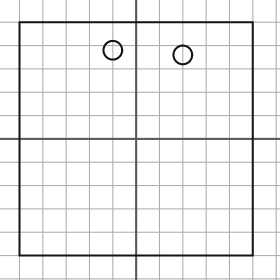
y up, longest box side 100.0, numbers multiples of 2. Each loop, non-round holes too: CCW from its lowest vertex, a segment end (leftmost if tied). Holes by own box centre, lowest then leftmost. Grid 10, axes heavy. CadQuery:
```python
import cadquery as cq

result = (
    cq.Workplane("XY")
    .moveTo(-50.0, -50.0)
    .lineTo(50.0, -50.0)
    .lineTo(50.0, 50.0)
    .lineTo(-50.0, 50.0)
    .close()
    .moveTo(20.0, 36.0)
    .circle(4.0)
    .moveTo(-10.0, 38.0)
    .circle(4.0)
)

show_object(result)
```